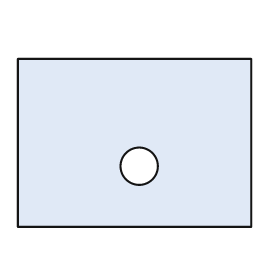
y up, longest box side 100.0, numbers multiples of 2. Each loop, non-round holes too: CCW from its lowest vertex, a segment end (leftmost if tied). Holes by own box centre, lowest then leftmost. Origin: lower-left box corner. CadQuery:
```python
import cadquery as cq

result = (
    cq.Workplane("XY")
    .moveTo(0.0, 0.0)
    .lineTo(100.0, 0.0)
    .lineTo(100.0, 72.0)
    .lineTo(0.0, 72.0)
    .close()
    .moveTo(52.0, 26.0)
    .circle(8.0)
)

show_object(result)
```